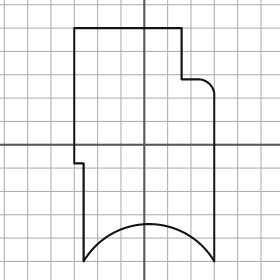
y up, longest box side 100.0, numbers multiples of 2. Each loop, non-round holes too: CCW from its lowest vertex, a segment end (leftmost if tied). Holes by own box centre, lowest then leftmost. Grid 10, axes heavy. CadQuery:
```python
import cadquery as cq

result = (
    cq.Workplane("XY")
    .moveTo(-26.0, -50.0)
    .threePointArc((2.0, -34.0), (30.0, -50.0))
    .lineTo(30.0, 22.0)
    .threePointArc((28.0, 26.0), (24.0, 28.0))
    .lineTo(16.0, 28.0)
    .lineTo(16.0, 50.0)
    .lineTo(-30.0, 50.0)
    .lineTo(-30.0, -8.0)
    .lineTo(-26.0, -8.0)
    .close()
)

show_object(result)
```